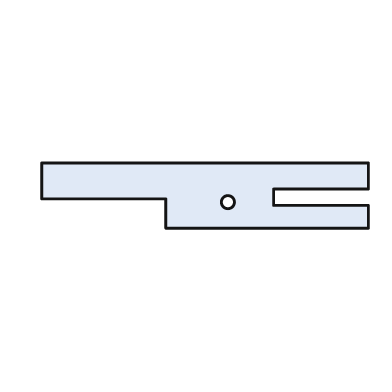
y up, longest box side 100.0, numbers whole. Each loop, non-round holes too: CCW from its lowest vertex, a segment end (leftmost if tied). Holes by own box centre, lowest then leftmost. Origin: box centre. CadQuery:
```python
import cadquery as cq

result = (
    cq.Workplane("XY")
    .moveTo(-12.0, -10.0)
    .lineTo(50.0, -10.0)
    .lineTo(50.0, -3.0)
    .lineTo(21.0, -3.0)
    .lineTo(21.0, 2.0)
    .lineTo(50.0, 2.0)
    .lineTo(50.0, 10.0)
    .lineTo(-50.0, 10.0)
    .lineTo(-50.0, -1.0)
    .lineTo(-12.0, -1.0)
    .close()
    .moveTo(7.0, -2.0)
    .circle(2.0)
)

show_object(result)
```